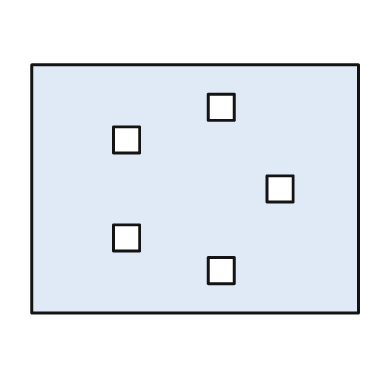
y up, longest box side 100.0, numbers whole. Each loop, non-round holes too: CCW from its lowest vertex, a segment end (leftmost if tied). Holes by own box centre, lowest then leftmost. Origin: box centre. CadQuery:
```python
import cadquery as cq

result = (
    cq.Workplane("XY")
    .moveTo(-50.0, -38.0)
    .lineTo(50.0, -38.0)
    .lineTo(50.0, 38.0)
    .lineTo(-50.0, 38.0)
    .close()
    .moveTo(4.0, -29.0)
    .lineTo(12.0, -29.0)
    .lineTo(12.0, -21.0)
    .lineTo(4.0, -21.0)
    .close()
    .moveTo(-25.0, -19.0)
    .lineTo(-17.0, -19.0)
    .lineTo(-17.0, -11.0)
    .lineTo(-25.0, -11.0)
    .close()
    .moveTo(22.0, -4.0)
    .lineTo(30.0, -4.0)
    .lineTo(30.0, 4.0)
    .lineTo(22.0, 4.0)
    .close()
    .moveTo(-25.0, 11.0)
    .lineTo(-17.0, 11.0)
    .lineTo(-17.0, 19.0)
    .lineTo(-25.0, 19.0)
    .close()
    .moveTo(4.0, 21.0)
    .lineTo(12.0, 21.0)
    .lineTo(12.0, 29.0)
    .lineTo(4.0, 29.0)
    .close()
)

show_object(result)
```